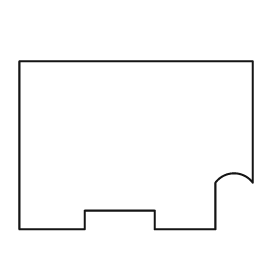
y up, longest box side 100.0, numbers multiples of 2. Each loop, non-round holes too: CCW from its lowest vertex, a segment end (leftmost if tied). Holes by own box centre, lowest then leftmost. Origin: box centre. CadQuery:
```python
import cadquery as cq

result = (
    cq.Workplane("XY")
    .moveTo(-50.0, -36.0)
    .lineTo(-22.0, -36.0)
    .lineTo(-22.0, -28.0)
    .lineTo(8.0, -28.0)
    .lineTo(8.0, -36.0)
    .lineTo(34.0, -36.0)
    .lineTo(34.0, -16.0)
    .threePointArc((42.0, -12.0), (50.0, -16.0))
    .lineTo(50.0, 36.0)
    .lineTo(-50.0, 36.0)
    .close()
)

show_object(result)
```